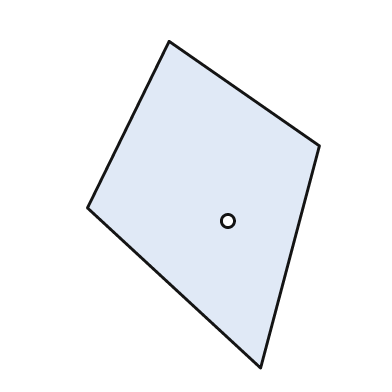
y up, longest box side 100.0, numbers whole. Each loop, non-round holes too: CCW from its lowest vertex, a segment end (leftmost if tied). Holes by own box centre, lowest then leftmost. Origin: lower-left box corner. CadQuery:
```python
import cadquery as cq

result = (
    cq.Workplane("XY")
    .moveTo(53.0, 0.0)
    .lineTo(71.0, 68.0)
    .lineTo(25.0, 100.0)
    .lineTo(0.0, 49.0)
    .close()
    .moveTo(43.0, 45.0)
    .circle(2.0)
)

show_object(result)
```